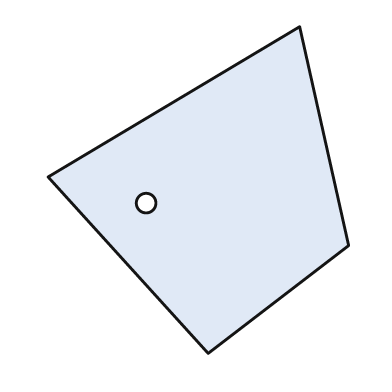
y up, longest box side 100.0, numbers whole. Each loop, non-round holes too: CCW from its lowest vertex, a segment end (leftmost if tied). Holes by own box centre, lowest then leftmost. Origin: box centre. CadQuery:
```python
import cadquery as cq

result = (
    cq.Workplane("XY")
    .moveTo(3.0, -50.0)
    .lineTo(46.0, -17.0)
    .lineTo(31.0, 50.0)
    .lineTo(-46.0, 4.0)
    .close()
    .moveTo(-16.0, -4.0)
    .circle(3.0)
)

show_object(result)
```